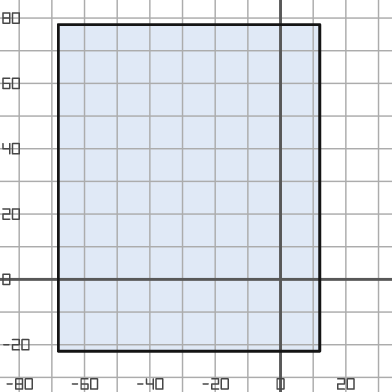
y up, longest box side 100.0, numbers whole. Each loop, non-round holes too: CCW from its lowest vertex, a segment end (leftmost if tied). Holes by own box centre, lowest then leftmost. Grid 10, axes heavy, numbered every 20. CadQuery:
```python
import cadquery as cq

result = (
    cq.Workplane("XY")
    .moveTo(-68.0, -22.0)
    .lineTo(12.0, -22.0)
    .lineTo(12.0, 78.0)
    .lineTo(-68.0, 78.0)
    .close()
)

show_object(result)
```